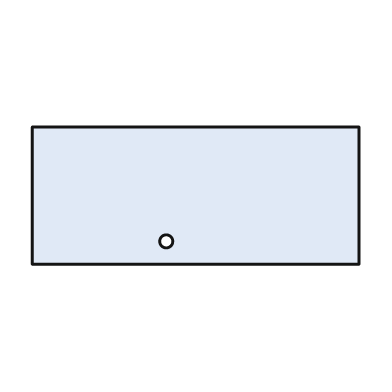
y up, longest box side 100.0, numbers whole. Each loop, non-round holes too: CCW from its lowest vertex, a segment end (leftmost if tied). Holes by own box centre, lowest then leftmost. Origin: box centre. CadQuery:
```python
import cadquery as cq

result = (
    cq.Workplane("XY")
    .moveTo(-50.0, -21.0)
    .lineTo(50.0, -21.0)
    .lineTo(50.0, 21.0)
    .lineTo(-50.0, 21.0)
    .close()
    .moveTo(-9.0, -14.0)
    .circle(2.0)
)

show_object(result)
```